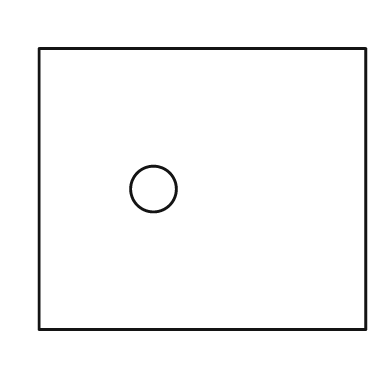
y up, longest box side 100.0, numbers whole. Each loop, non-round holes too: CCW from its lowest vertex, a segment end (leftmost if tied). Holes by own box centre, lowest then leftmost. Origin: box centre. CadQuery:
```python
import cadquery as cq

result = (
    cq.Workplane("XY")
    .moveTo(-50.0, -43.0)
    .lineTo(50.0, -43.0)
    .lineTo(50.0, 43.0)
    .lineTo(-50.0, 43.0)
    .close()
    .moveTo(-15.0, 0.0)
    .circle(7.0)
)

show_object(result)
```